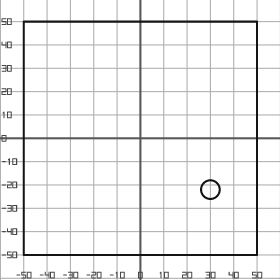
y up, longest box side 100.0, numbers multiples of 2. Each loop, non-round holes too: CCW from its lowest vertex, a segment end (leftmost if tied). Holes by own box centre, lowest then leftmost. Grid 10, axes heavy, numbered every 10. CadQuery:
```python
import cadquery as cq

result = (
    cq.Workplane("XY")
    .moveTo(-50.0, -50.0)
    .lineTo(50.0, -50.0)
    .lineTo(50.0, 50.0)
    .lineTo(-50.0, 50.0)
    .close()
    .moveTo(30.0, -22.0)
    .circle(4.0)
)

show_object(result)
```